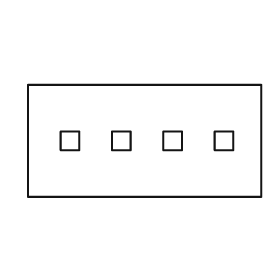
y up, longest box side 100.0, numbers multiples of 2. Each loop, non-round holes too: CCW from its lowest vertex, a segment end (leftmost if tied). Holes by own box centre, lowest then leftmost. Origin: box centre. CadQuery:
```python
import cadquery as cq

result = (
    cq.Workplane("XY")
    .moveTo(-50.0, -24.0)
    .lineTo(50.0, -24.0)
    .lineTo(50.0, 24.0)
    .lineTo(-50.0, 24.0)
    .close()
    .moveTo(-36.0, -4.0)
    .lineTo(-28.0, -4.0)
    .lineTo(-28.0, 4.0)
    .lineTo(-36.0, 4.0)
    .close()
    .moveTo(-14.0, -4.0)
    .lineTo(-6.0, -4.0)
    .lineTo(-6.0, 4.0)
    .lineTo(-14.0, 4.0)
    .close()
    .moveTo(8.0, -4.0)
    .lineTo(16.0, -4.0)
    .lineTo(16.0, 4.0)
    .lineTo(8.0, 4.0)
    .close()
    .moveTo(30.0, -4.0)
    .lineTo(38.0, -4.0)
    .lineTo(38.0, 4.0)
    .lineTo(30.0, 4.0)
    .close()
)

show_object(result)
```